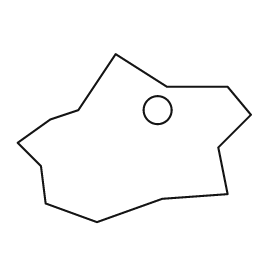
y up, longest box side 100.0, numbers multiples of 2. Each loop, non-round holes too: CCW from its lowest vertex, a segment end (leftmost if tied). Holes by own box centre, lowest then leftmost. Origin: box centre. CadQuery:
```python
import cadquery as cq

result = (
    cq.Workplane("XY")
    .moveTo(-16.0, -36.0)
    .lineTo(12.0, -26.0)
    .lineTo(40.0, -24.0)
    .lineTo(36.0, -4.0)
    .lineTo(50.0, 10.0)
    .lineTo(40.0, 22.0)
    .lineTo(14.0, 22.0)
    .lineTo(-8.0, 36.0)
    .lineTo(-24.0, 12.0)
    .lineTo(-36.0, 8.0)
    .lineTo(-50.0, -2.0)
    .lineTo(-40.0, -12.0)
    .lineTo(-38.0, -28.0)
    .close()
    .moveTo(10.0, 12.0)
    .circle(6.0)
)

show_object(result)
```